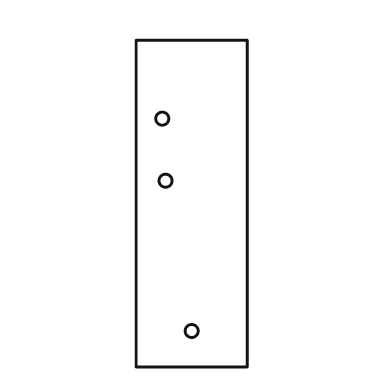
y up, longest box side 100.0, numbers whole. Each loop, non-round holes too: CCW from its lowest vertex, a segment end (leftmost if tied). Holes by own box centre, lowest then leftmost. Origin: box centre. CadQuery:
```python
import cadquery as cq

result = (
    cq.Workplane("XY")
    .moveTo(-17.0, -50.0)
    .lineTo(17.0, -50.0)
    .lineTo(17.0, 50.0)
    .lineTo(-17.0, 50.0)
    .close()
    .moveTo(0.0, -39.0)
    .circle(2.0)
    .moveTo(-8.0, 7.0)
    .circle(2.0)
    .moveTo(-9.0, 26.0)
    .circle(2.0)
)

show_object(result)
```